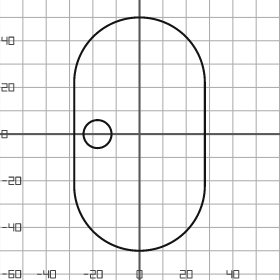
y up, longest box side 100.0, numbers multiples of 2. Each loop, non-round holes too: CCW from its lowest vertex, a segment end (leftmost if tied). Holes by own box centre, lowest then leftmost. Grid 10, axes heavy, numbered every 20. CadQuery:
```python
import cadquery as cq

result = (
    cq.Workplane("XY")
    .moveTo(-28.0, -22.0)
    .threePointArc((0.0, -50.0), (28.0, -22.0))
    .lineTo(28.0, 22.0)
    .threePointArc((0.0, 50.0), (-28.0, 22.0))
    .close()
    .moveTo(-18.0, 0.0)
    .circle(6.0)
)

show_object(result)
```